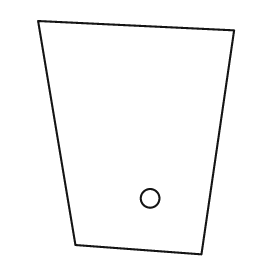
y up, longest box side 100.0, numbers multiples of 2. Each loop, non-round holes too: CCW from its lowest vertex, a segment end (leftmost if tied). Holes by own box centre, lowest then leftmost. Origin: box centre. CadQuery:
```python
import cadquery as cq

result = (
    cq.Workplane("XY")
    .moveTo(28.0, -50.0)
    .lineTo(42.0, 46.0)
    .lineTo(-42.0, 50.0)
    .lineTo(-26.0, -46.0)
    .close()
    .moveTo(6.0, -26.0)
    .circle(4.0)
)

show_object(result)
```